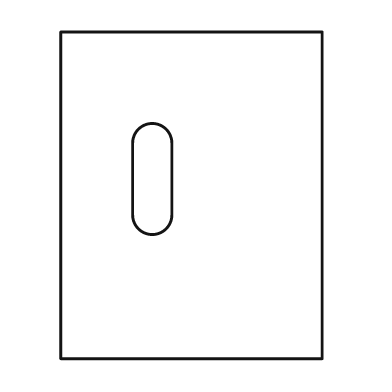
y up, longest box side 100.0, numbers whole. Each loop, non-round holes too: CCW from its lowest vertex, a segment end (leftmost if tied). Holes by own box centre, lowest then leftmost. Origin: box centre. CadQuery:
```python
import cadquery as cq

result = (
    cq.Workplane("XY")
    .moveTo(-40.0, -50.0)
    .lineTo(40.0, -50.0)
    .lineTo(40.0, 50.0)
    .lineTo(-40.0, 50.0)
    .close()
    .moveTo(-18.0, -6.0)
    .threePointArc((-12.0, -12.0), (-6.0, -6.0))
    .lineTo(-6.0, 16.0)
    .threePointArc((-12.0, 22.0), (-18.0, 16.0))
    .close()
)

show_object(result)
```